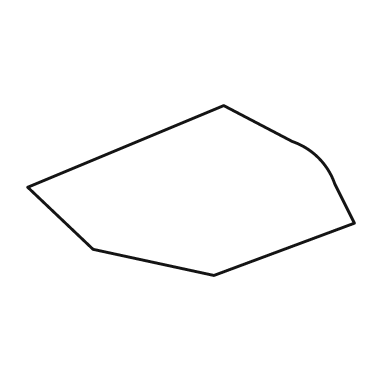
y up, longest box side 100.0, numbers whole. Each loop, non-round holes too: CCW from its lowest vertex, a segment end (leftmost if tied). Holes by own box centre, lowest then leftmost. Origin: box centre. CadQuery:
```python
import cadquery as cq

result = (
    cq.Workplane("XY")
    .moveTo(7.0, -26.0)
    .lineTo(50.0, -10.0)
    .lineTo(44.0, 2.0)
    .threePointArc((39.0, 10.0), (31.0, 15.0))
    .lineTo(10.0, 26.0)
    .lineTo(-50.0, 1.0)
    .lineTo(-30.0, -18.0)
    .close()
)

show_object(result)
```